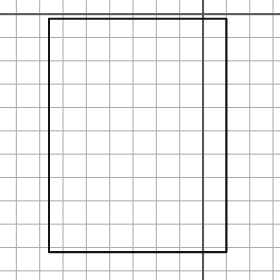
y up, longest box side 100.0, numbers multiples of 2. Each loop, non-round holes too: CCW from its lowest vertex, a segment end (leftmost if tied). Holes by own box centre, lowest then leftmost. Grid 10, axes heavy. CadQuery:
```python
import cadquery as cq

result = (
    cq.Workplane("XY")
    .moveTo(-66.0, -102.0)
    .lineTo(10.0, -102.0)
    .lineTo(10.0, -2.0)
    .lineTo(-66.0, -2.0)
    .close()
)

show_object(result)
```